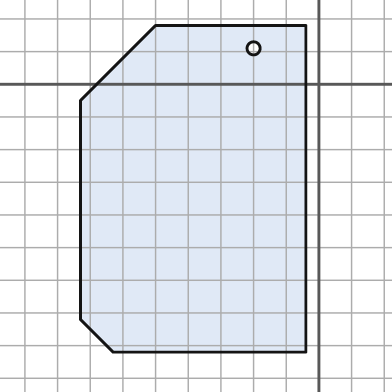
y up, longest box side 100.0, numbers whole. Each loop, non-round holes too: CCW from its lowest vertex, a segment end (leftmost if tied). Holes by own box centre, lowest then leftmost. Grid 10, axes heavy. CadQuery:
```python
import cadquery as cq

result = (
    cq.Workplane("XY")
    .moveTo(-63.0, -82.0)
    .lineTo(-4.0, -82.0)
    .lineTo(-4.0, 18.0)
    .lineTo(-50.0, 18.0)
    .lineTo(-73.0, -5.0)
    .lineTo(-73.0, -72.0)
    .close()
    .moveTo(-20.0, 11.0)
    .circle(2.0)
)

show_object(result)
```